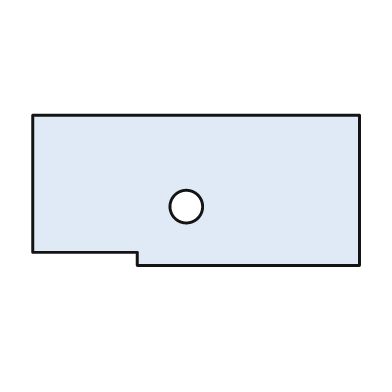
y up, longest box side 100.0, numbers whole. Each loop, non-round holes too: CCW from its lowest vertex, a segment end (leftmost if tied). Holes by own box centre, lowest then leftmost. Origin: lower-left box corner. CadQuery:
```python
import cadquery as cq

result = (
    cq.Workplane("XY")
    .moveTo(32.0, 0.0)
    .lineTo(100.0, 0.0)
    .lineTo(100.0, 46.0)
    .lineTo(0.0, 46.0)
    .lineTo(0.0, 4.0)
    .lineTo(32.0, 4.0)
    .close()
    .moveTo(47.0, 18.0)
    .circle(5.0)
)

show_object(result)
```